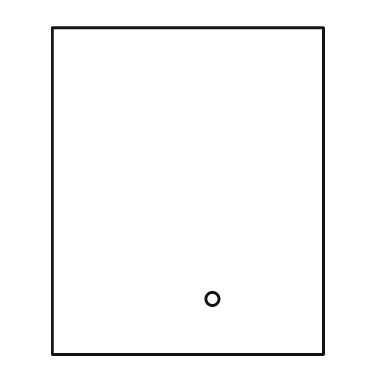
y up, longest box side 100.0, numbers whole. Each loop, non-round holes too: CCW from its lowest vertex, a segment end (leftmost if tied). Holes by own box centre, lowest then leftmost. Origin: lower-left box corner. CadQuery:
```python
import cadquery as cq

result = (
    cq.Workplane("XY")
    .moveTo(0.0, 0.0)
    .lineTo(83.0, 0.0)
    .lineTo(83.0, 100.0)
    .lineTo(0.0, 100.0)
    .close()
    .moveTo(49.0, 17.0)
    .circle(2.0)
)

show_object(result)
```